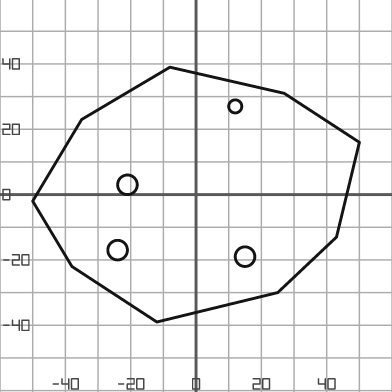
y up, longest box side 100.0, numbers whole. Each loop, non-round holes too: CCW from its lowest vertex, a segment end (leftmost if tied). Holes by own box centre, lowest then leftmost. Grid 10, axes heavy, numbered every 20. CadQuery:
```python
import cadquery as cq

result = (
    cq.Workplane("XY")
    .moveTo(-12.0, -39.0)
    .lineTo(25.0, -30.0)
    .lineTo(43.0, -13.0)
    .lineTo(50.0, 16.0)
    .lineTo(27.0, 31.0)
    .lineTo(-8.0, 39.0)
    .lineTo(-35.0, 23.0)
    .lineTo(-50.0, -2.0)
    .lineTo(-38.0, -22.0)
    .close()
    .moveTo(15.0, -19.0)
    .circle(3.0)
    .moveTo(-24.0, -17.0)
    .circle(3.0)
    .moveTo(-21.0, 3.0)
    .circle(3.0)
    .moveTo(12.0, 27.0)
    .circle(2.0)
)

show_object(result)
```